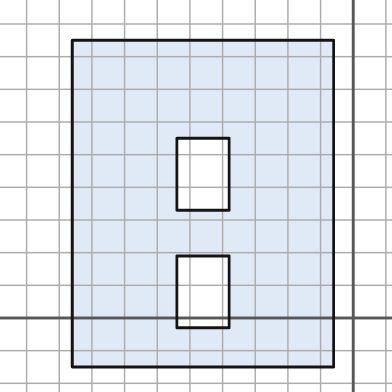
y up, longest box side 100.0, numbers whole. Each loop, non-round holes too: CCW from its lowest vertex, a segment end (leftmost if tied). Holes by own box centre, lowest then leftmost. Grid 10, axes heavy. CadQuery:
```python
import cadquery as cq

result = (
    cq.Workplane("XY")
    .moveTo(-86.0, -15.0)
    .lineTo(-6.0, -15.0)
    .lineTo(-6.0, 85.0)
    .lineTo(-86.0, 85.0)
    .close()
    .moveTo(-54.0, -3.0)
    .lineTo(-38.0, -3.0)
    .lineTo(-38.0, 19.0)
    .lineTo(-54.0, 19.0)
    .close()
    .moveTo(-54.0, 33.0)
    .lineTo(-38.0, 33.0)
    .lineTo(-38.0, 55.0)
    .lineTo(-54.0, 55.0)
    .close()
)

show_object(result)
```